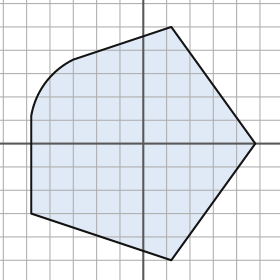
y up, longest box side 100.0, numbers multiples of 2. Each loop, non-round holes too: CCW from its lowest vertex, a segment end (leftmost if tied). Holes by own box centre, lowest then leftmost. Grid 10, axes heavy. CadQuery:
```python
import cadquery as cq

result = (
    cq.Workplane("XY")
    .moveTo(12.0, -50.0)
    .lineTo(48.0, 0.0)
    .lineTo(12.0, 50.0)
    .lineTo(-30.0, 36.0)
    .threePointArc((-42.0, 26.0), (-48.0, 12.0))
    .lineTo(-48.0, -30.0)
    .close()
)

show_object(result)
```